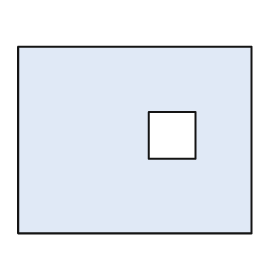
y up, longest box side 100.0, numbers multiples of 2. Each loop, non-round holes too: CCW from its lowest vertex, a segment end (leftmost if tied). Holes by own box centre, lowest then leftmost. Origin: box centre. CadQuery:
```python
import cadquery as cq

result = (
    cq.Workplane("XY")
    .moveTo(-50.0, -40.0)
    .lineTo(50.0, -40.0)
    .lineTo(50.0, 40.0)
    .lineTo(-50.0, 40.0)
    .close()
    .moveTo(6.0, -8.0)
    .lineTo(26.0, -8.0)
    .lineTo(26.0, 12.0)
    .lineTo(6.0, 12.0)
    .close()
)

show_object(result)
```